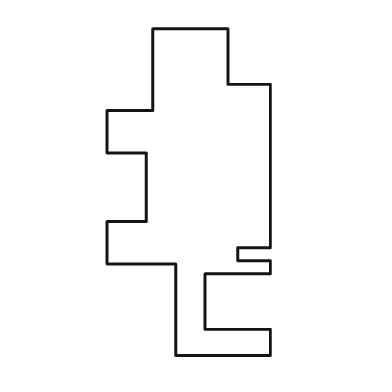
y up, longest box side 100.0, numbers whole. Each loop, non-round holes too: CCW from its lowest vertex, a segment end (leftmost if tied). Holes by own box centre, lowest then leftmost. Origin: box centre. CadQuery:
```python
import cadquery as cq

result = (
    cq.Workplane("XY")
    .moveTo(-4.0, -50.0)
    .lineTo(25.0, -50.0)
    .lineTo(25.0, -42.0)
    .lineTo(5.0, -42.0)
    .lineTo(5.0, -25.0)
    .lineTo(25.0, -25.0)
    .lineTo(25.0, -21.0)
    .lineTo(15.0, -21.0)
    .lineTo(15.0, -17.0)
    .lineTo(25.0, -17.0)
    .lineTo(25.0, 33.0)
    .lineTo(12.0, 33.0)
    .lineTo(12.0, 50.0)
    .lineTo(-11.0, 50.0)
    .lineTo(-11.0, 25.0)
    .lineTo(-25.0, 25.0)
    .lineTo(-25.0, 12.0)
    .lineTo(-13.0, 12.0)
    .lineTo(-13.0, -9.0)
    .lineTo(-25.0, -9.0)
    .lineTo(-25.0, -22.0)
    .lineTo(-4.0, -22.0)
    .close()
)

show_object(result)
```